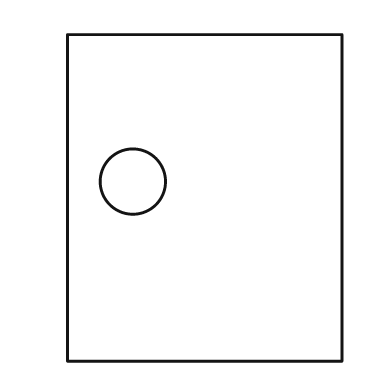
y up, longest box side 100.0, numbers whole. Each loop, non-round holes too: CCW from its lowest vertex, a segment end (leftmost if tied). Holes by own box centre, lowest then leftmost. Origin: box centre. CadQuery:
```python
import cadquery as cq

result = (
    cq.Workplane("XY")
    .moveTo(-42.0, -50.0)
    .lineTo(42.0, -50.0)
    .lineTo(42.0, 50.0)
    .lineTo(-42.0, 50.0)
    .close()
    .moveTo(-22.0, 5.0)
    .circle(10.0)
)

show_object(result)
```